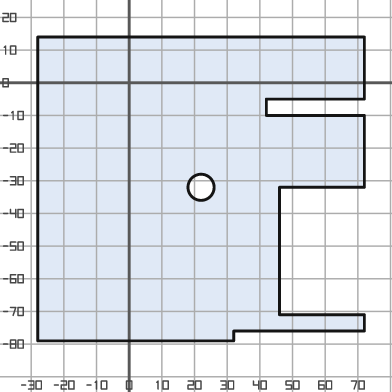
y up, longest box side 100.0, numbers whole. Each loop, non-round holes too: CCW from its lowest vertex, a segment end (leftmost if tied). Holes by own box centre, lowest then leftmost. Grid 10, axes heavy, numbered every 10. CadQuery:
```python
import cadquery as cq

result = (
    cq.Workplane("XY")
    .moveTo(-28.0, -79.0)
    .lineTo(32.0, -79.0)
    .lineTo(32.0, -76.0)
    .lineTo(72.0, -76.0)
    .lineTo(72.0, -71.0)
    .lineTo(46.0, -71.0)
    .lineTo(46.0, -32.0)
    .lineTo(72.0, -32.0)
    .lineTo(72.0, -10.0)
    .lineTo(42.0, -10.0)
    .lineTo(42.0, -5.0)
    .lineTo(72.0, -5.0)
    .lineTo(72.0, 14.0)
    .lineTo(-28.0, 14.0)
    .close()
    .moveTo(22.0, -32.0)
    .circle(4.0)
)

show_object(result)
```